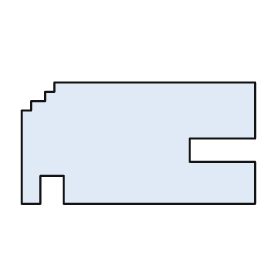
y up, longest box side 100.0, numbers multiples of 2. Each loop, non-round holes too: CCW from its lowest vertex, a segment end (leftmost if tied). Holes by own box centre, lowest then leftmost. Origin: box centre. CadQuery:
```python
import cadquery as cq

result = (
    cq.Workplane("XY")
    .moveTo(-50.0, -26.0)
    .lineTo(-42.0, -26.0)
    .lineTo(-42.0, -14.0)
    .lineTo(-32.0, -14.0)
    .lineTo(-32.0, -26.0)
    .lineTo(50.0, -26.0)
    .lineTo(50.0, -8.0)
    .lineTo(22.0, -8.0)
    .lineTo(22.0, 2.0)
    .lineTo(50.0, 2.0)
    .lineTo(50.0, 26.0)
    .lineTo(-36.0, 26.0)
    .lineTo(-36.0, 22.0)
    .lineTo(-40.0, 22.0)
    .lineTo(-40.0, 18.0)
    .lineTo(-46.0, 18.0)
    .lineTo(-46.0, 14.0)
    .lineTo(-50.0, 14.0)
    .close()
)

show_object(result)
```